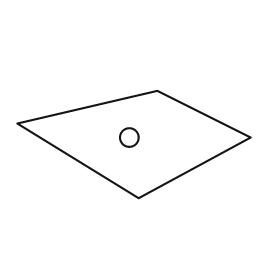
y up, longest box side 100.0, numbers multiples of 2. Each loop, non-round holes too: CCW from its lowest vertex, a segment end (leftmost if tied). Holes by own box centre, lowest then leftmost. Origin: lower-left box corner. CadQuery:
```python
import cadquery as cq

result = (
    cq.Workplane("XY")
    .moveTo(52.0, 0.0)
    .lineTo(100.0, 26.0)
    .lineTo(60.0, 46.0)
    .lineTo(0.0, 32.0)
    .close()
    .moveTo(48.0, 26.0)
    .circle(4.0)
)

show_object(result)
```